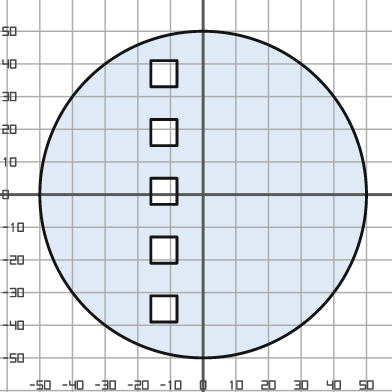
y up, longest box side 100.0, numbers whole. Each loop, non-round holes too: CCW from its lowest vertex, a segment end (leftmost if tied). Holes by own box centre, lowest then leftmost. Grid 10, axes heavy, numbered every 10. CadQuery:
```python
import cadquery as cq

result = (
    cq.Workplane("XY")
    .moveTo(0.0, 0.0)
    .circle(50.0)
    .moveTo(-16.0, -39.0)
    .lineTo(-8.0, -39.0)
    .lineTo(-8.0, -31.0)
    .lineTo(-16.0, -31.0)
    .close()
    .moveTo(-16.0, -21.0)
    .lineTo(-8.0, -21.0)
    .lineTo(-8.0, -13.0)
    .lineTo(-16.0, -13.0)
    .close()
    .moveTo(-16.0, -3.0)
    .lineTo(-8.0, -3.0)
    .lineTo(-8.0, 5.0)
    .lineTo(-16.0, 5.0)
    .close()
    .moveTo(-16.0, 15.0)
    .lineTo(-8.0, 15.0)
    .lineTo(-8.0, 23.0)
    .lineTo(-16.0, 23.0)
    .close()
    .moveTo(-16.0, 33.0)
    .lineTo(-8.0, 33.0)
    .lineTo(-8.0, 41.0)
    .lineTo(-16.0, 41.0)
    .close()
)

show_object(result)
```